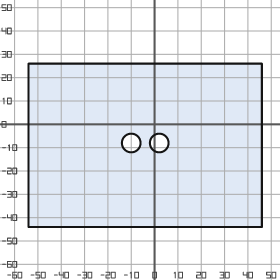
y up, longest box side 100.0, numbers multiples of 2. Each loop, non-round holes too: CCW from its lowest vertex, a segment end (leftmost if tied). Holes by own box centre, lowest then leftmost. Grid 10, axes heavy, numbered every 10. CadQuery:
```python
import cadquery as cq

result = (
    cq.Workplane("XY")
    .moveTo(-54.0, -44.0)
    .lineTo(46.0, -44.0)
    .lineTo(46.0, 26.0)
    .lineTo(-54.0, 26.0)
    .close()
    .moveTo(-10.0, -8.0)
    .circle(4.0)
    .moveTo(2.0, -8.0)
    .circle(4.0)
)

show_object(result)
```